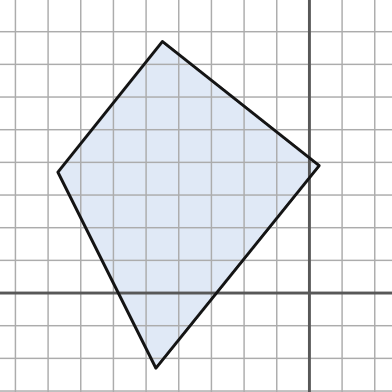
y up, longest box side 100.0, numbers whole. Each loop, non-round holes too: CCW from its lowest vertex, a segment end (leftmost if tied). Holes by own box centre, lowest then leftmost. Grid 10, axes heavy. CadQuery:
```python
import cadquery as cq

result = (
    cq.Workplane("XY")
    .moveTo(-47.0, -23.0)
    .lineTo(3.0, 39.0)
    .lineTo(-45.0, 77.0)
    .lineTo(-77.0, 37.0)
    .close()
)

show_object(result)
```